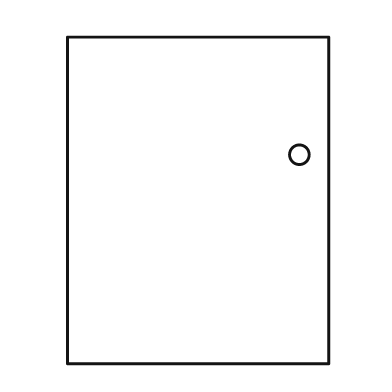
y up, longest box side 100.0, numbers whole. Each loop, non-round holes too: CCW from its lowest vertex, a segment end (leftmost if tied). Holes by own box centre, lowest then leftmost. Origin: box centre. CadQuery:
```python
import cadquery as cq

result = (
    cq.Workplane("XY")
    .moveTo(-40.0, -50.0)
    .lineTo(40.0, -50.0)
    .lineTo(40.0, 50.0)
    .lineTo(-40.0, 50.0)
    .close()
    .moveTo(31.0, 14.0)
    .circle(3.0)
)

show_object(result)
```